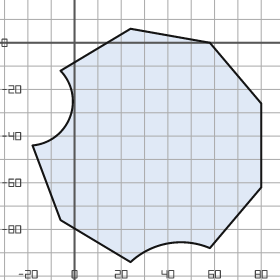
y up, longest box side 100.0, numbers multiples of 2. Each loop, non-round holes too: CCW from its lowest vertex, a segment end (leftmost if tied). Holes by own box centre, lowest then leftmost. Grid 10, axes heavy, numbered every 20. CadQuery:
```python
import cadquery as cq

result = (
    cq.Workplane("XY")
    .moveTo(24.0, -94.0)
    .threePointArc((40.0, -86.0), (58.0, -88.0))
    .lineTo(80.0, -62.0)
    .lineTo(80.0, -26.0)
    .lineTo(58.0, 0.0)
    .lineTo(24.0, 6.0)
    .lineTo(-6.0, -12.0)
    .threePointArc((-2.0, -32.0), (-18.0, -44.0))
    .lineTo(-6.0, -76.0)
    .close()
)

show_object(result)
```